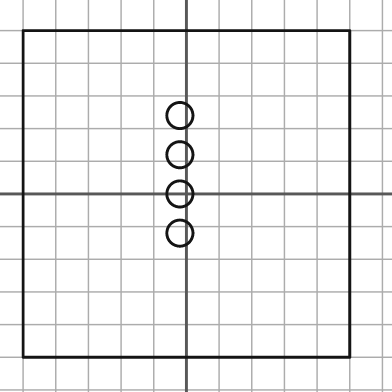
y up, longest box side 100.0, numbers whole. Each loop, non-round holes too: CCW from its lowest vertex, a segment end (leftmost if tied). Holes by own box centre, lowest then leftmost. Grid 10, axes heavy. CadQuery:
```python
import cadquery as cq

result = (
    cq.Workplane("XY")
    .moveTo(-50.0, -50.0)
    .lineTo(50.0, -50.0)
    .lineTo(50.0, 50.0)
    .lineTo(-50.0, 50.0)
    .close()
    .moveTo(-2.0, -12.0)
    .circle(4.0)
    .moveTo(-2.0, 0.0)
    .circle(4.0)
    .moveTo(-2.0, 12.0)
    .circle(4.0)
    .moveTo(-2.0, 24.0)
    .circle(4.0)
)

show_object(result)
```